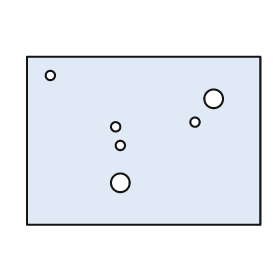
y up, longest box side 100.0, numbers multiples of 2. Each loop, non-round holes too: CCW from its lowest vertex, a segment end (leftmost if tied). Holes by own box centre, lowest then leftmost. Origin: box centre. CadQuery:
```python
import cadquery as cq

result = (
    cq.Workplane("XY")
    .moveTo(-50.0, -36.0)
    .lineTo(50.0, -36.0)
    .lineTo(50.0, 36.0)
    .lineTo(-50.0, 36.0)
    .close()
    .moveTo(-10.0, -18.0)
    .circle(4.0)
    .moveTo(-10.0, -2.0)
    .circle(2.0)
    .moveTo(-12.0, 6.0)
    .circle(2.0)
    .moveTo(22.0, 8.0)
    .circle(2.0)
    .moveTo(30.0, 18.0)
    .circle(4.0)
    .moveTo(-40.0, 28.0)
    .circle(2.0)
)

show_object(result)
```